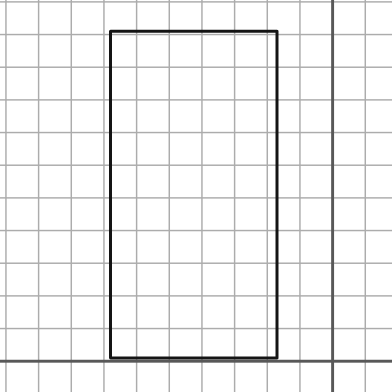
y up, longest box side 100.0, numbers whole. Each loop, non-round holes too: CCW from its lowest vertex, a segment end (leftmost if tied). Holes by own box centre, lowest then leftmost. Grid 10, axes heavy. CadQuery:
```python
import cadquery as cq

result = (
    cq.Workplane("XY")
    .moveTo(-68.0, 1.0)
    .lineTo(-17.0, 1.0)
    .lineTo(-17.0, 101.0)
    .lineTo(-68.0, 101.0)
    .close()
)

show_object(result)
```